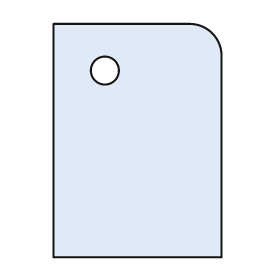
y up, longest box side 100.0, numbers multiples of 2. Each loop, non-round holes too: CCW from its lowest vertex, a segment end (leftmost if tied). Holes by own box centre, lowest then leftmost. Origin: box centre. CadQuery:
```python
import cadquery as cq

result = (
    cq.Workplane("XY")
    .moveTo(-36.0, -50.0)
    .lineTo(36.0, -50.0)
    .lineTo(36.0, 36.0)
    .threePointArc((32.0, 46.0), (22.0, 50.0))
    .lineTo(-36.0, 50.0)
    .close()
    .moveTo(-14.0, 30.0)
    .circle(6.0)
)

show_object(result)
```